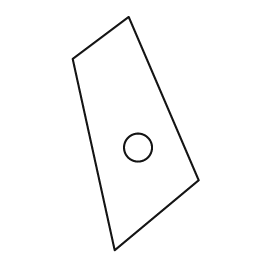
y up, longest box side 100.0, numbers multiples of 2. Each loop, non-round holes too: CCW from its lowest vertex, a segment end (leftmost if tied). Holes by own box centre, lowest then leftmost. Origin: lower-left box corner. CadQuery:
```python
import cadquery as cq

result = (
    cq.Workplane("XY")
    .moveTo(18.0, 0.0)
    .lineTo(54.0, 30.0)
    .lineTo(24.0, 100.0)
    .lineTo(0.0, 82.0)
    .close()
    .moveTo(28.0, 44.0)
    .circle(6.0)
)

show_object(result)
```